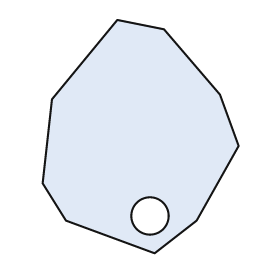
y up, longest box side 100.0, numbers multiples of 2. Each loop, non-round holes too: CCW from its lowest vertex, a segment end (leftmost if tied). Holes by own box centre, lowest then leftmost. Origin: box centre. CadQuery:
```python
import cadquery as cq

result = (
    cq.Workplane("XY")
    .moveTo(6.0, -50.0)
    .lineTo(24.0, -36.0)
    .lineTo(42.0, -4.0)
    .lineTo(34.0, 18.0)
    .lineTo(10.0, 46.0)
    .lineTo(-10.0, 50.0)
    .lineTo(-38.0, 16.0)
    .lineTo(-42.0, -20.0)
    .lineTo(-32.0, -36.0)
    .close()
    .moveTo(4.0, -34.0)
    .circle(8.0)
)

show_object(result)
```